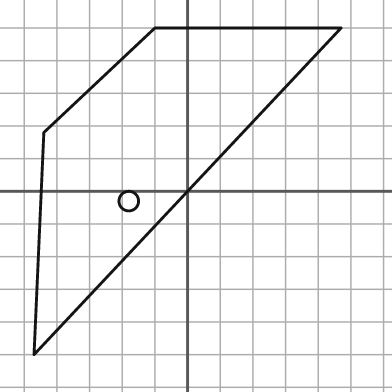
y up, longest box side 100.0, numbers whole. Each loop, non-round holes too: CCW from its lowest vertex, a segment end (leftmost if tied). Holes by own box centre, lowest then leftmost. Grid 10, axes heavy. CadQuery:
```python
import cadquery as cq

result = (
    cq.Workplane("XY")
    .moveTo(-47.0, -50.0)
    .lineTo(47.0, 50.0)
    .lineTo(-10.0, 50.0)
    .lineTo(-44.0, 18.0)
    .close()
    .moveTo(-18.0, -3.0)
    .circle(3.0)
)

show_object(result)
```